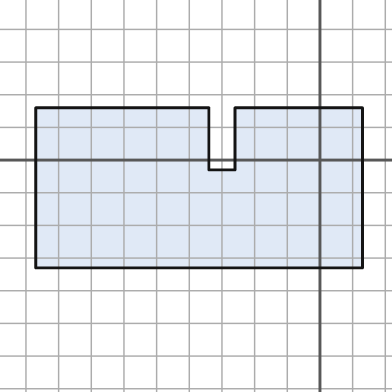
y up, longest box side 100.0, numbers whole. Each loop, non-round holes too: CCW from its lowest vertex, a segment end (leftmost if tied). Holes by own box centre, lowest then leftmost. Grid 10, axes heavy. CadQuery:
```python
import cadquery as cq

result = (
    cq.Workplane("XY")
    .moveTo(-87.0, -33.0)
    .lineTo(13.0, -33.0)
    .lineTo(13.0, 16.0)
    .lineTo(-26.0, 16.0)
    .lineTo(-26.0, -3.0)
    .lineTo(-34.0, -3.0)
    .lineTo(-34.0, 16.0)
    .lineTo(-87.0, 16.0)
    .close()
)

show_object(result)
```